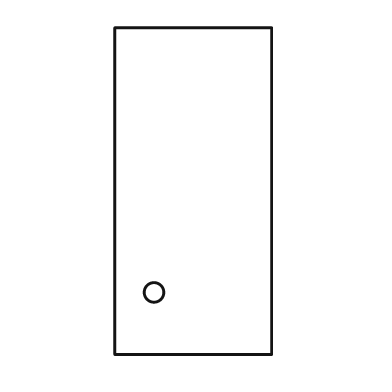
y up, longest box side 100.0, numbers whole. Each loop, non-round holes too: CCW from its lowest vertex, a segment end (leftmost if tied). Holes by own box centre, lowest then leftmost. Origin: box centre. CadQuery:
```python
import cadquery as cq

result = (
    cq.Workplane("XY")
    .moveTo(-24.0, -50.0)
    .lineTo(24.0, -50.0)
    .lineTo(24.0, 50.0)
    .lineTo(-24.0, 50.0)
    .close()
    .moveTo(-12.0, -31.0)
    .circle(3.0)
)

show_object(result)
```